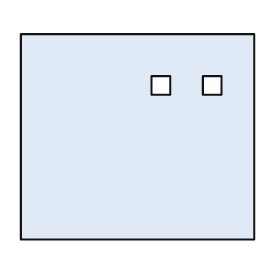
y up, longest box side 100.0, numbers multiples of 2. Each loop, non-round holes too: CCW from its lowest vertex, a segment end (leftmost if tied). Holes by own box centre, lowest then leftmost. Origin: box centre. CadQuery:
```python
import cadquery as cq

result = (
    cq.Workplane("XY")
    .moveTo(-50.0, -44.0)
    .lineTo(50.0, -44.0)
    .lineTo(50.0, 44.0)
    .lineTo(-50.0, 44.0)
    .close()
    .moveTo(6.0, 18.0)
    .lineTo(14.0, 18.0)
    .lineTo(14.0, 26.0)
    .lineTo(6.0, 26.0)
    .close()
    .moveTo(28.0, 18.0)
    .lineTo(36.0, 18.0)
    .lineTo(36.0, 26.0)
    .lineTo(28.0, 26.0)
    .close()
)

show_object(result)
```